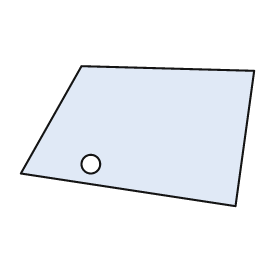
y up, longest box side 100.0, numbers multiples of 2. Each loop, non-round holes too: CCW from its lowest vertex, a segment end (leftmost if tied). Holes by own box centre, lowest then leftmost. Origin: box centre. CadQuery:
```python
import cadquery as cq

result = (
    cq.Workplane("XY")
    .moveTo(42.0, -30.0)
    .lineTo(50.0, 28.0)
    .lineTo(-24.0, 30.0)
    .lineTo(-50.0, -16.0)
    .close()
    .moveTo(-20.0, -12.0)
    .circle(4.0)
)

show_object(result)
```